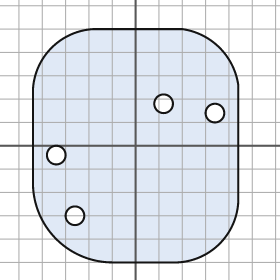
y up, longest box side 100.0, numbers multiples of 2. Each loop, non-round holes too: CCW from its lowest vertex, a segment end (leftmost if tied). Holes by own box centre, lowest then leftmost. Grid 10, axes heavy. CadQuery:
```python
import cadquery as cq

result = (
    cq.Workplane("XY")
    .moveTo(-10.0, -50.0)
    .lineTo(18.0, -50.0)
    .threePointArc((36.0, -42.0), (44.0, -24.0))
    .lineTo(44.0, 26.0)
    .threePointArc((36.0, 42.0), (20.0, 50.0))
    .lineTo(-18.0, 50.0)
    .threePointArc((-36.0, 42.0), (-44.0, 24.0))
    .lineTo(-44.0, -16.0)
    .threePointArc((-34.0, -40.0), (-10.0, -50.0))
    .close()
    .moveTo(-26.0, -30.0)
    .circle(4.0)
    .moveTo(-34.0, -4.0)
    .circle(4.0)
    .moveTo(34.0, 14.0)
    .circle(4.0)
    .moveTo(12.0, 18.0)
    .circle(4.0)
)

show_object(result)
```